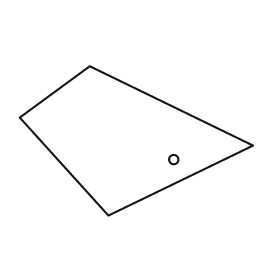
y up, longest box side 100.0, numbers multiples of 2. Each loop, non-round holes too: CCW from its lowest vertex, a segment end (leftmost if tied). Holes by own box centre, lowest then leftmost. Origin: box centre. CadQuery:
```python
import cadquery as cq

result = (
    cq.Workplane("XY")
    .moveTo(-12.0, -32.0)
    .lineTo(50.0, -2.0)
    .lineTo(-20.0, 32.0)
    .lineTo(-50.0, 10.0)
    .close()
    .moveTo(16.0, -8.0)
    .circle(2.0)
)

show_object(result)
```